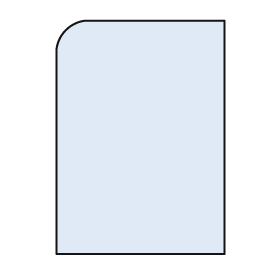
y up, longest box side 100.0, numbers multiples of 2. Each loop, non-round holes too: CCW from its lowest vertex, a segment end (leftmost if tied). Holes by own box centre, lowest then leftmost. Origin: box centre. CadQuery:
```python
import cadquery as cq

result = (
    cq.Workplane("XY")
    .moveTo(-36.0, -50.0)
    .lineTo(36.0, -50.0)
    .lineTo(36.0, 50.0)
    .lineTo(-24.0, 50.0)
    .threePointArc((-32.0, 46.0), (-36.0, 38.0))
    .close()
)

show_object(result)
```